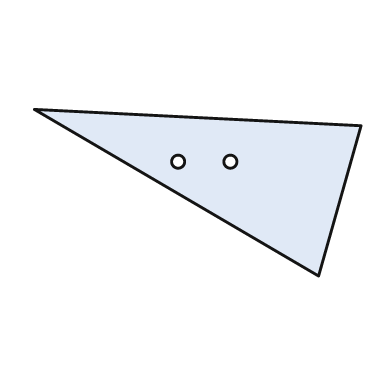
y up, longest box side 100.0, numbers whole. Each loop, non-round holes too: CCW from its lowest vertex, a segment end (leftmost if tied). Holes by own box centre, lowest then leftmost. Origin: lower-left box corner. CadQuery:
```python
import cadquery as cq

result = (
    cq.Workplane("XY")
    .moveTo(87.0, 0.0)
    .lineTo(100.0, 46.0)
    .lineTo(0.0, 51.0)
    .close()
    .moveTo(44.0, 35.0)
    .circle(2.0)
    .moveTo(60.0, 35.0)
    .circle(2.0)
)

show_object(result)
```